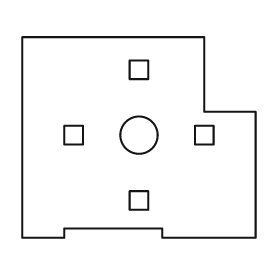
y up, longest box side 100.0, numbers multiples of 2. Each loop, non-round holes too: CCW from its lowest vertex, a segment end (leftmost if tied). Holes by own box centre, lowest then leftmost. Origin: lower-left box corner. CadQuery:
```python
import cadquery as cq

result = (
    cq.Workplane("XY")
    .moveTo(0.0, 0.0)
    .lineTo(18.0, 0.0)
    .lineTo(18.0, 4.0)
    .lineTo(60.0, 4.0)
    .lineTo(60.0, 0.0)
    .lineTo(100.0, 0.0)
    .lineTo(100.0, 54.0)
    .lineTo(78.0, 54.0)
    .lineTo(78.0, 86.0)
    .lineTo(0.0, 86.0)
    .close()
    .moveTo(46.0, 12.0)
    .lineTo(54.0, 12.0)
    .lineTo(54.0, 20.0)
    .lineTo(46.0, 20.0)
    .close()
    .moveTo(18.0, 40.0)
    .lineTo(26.0, 40.0)
    .lineTo(26.0, 48.0)
    .lineTo(18.0, 48.0)
    .close()
    .moveTo(50.0, 44.0)
    .circle(8.0)
    .moveTo(74.0, 40.0)
    .lineTo(82.0, 40.0)
    .lineTo(82.0, 48.0)
    .lineTo(74.0, 48.0)
    .close()
    .moveTo(46.0, 68.0)
    .lineTo(54.0, 68.0)
    .lineTo(54.0, 76.0)
    .lineTo(46.0, 76.0)
    .close()
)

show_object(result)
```